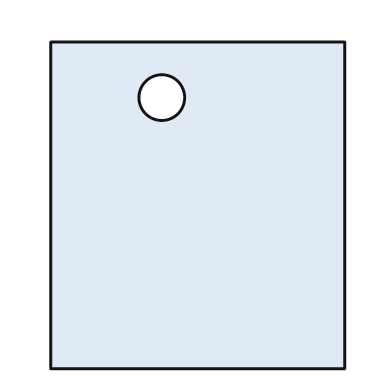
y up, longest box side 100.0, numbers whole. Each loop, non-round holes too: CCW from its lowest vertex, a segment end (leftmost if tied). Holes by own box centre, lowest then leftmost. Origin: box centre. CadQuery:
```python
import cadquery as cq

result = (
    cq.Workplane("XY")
    .moveTo(-45.0, -50.0)
    .lineTo(45.0, -50.0)
    .lineTo(45.0, 50.0)
    .lineTo(-45.0, 50.0)
    .close()
    .moveTo(-11.0, 33.0)
    .circle(7.0)
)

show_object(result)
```